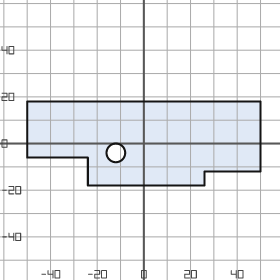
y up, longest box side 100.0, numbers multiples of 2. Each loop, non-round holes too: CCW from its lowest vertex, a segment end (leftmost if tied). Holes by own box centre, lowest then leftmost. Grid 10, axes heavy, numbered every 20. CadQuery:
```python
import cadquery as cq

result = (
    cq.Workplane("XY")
    .moveTo(-24.0, -18.0)
    .lineTo(26.0, -18.0)
    .lineTo(26.0, -12.0)
    .lineTo(50.0, -12.0)
    .lineTo(50.0, 18.0)
    .lineTo(-50.0, 18.0)
    .lineTo(-50.0, -6.0)
    .lineTo(-24.0, -6.0)
    .close()
    .moveTo(-12.0, -4.0)
    .circle(4.0)
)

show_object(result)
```